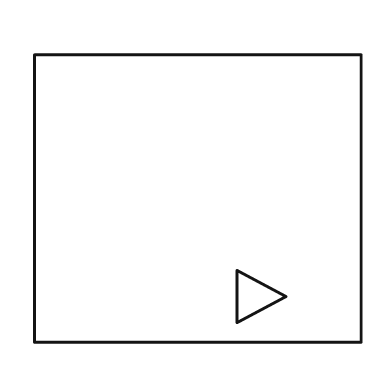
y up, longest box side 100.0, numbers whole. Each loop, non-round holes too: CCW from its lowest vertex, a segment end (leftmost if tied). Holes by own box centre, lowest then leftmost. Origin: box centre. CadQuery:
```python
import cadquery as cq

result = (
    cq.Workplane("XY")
    .moveTo(-50.0, -44.0)
    .lineTo(50.0, -44.0)
    .lineTo(50.0, 44.0)
    .lineTo(-50.0, 44.0)
    .close()
    .moveTo(12.0, -38.0)
    .lineTo(27.0, -30.0)
    .lineTo(12.0, -22.0)
    .close()
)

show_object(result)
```